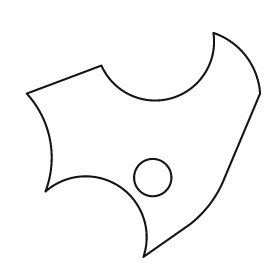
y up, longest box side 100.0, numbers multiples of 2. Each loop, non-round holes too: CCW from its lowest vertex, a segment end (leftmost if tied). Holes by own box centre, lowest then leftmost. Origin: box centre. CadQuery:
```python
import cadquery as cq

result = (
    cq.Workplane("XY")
    .moveTo(0.0, -48.0)
    .lineTo(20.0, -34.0)
    .threePointArc((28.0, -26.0), (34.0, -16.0))
    .lineTo(50.0, 22.0)
    .threePointArc((44.0, 38.0), (30.0, 48.0))
    .threePointArc((12.0, 20.0), (-18.0, 34.0))
    .lineTo(-50.0, 22.0)
    .threePointArc((-40.0, 2.0), (-42.0, -20.0))
    .threePointArc((-10.0, -18.0), (0.0, -48.0))
    .close()
    .moveTo(4.0, -14.0)
    .circle(8.0)
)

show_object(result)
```